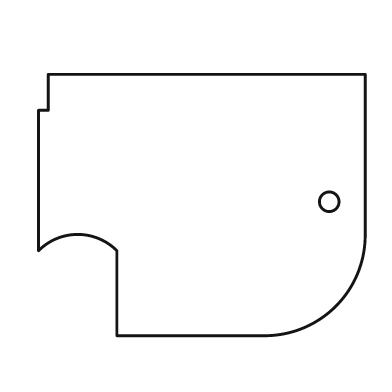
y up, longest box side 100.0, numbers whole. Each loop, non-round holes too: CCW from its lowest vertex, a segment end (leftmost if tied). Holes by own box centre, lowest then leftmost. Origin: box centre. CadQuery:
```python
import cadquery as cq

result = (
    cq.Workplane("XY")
    .moveTo(-26.0, -40.0)
    .lineTo(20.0, -40.0)
    .threePointArc((41.0, -31.0), (50.0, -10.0))
    .lineTo(50.0, 40.0)
    .lineTo(-47.0, 40.0)
    .lineTo(-47.0, 29.0)
    .lineTo(-50.0, 29.0)
    .lineTo(-50.0, -14.0)
    .threePointArc((-38.0, -9.0), (-26.0, -14.0))
    .close()
    .moveTo(39.0, 1.0)
    .circle(3.0)
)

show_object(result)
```